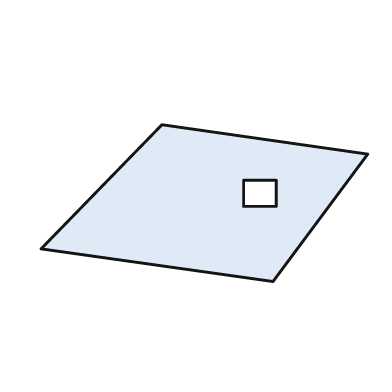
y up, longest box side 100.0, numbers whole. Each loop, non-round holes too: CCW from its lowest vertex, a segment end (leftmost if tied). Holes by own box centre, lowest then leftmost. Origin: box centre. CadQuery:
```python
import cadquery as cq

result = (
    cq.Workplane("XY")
    .moveTo(21.0, -24.0)
    .lineTo(50.0, 15.0)
    .lineTo(-13.0, 24.0)
    .lineTo(-50.0, -14.0)
    .close()
    .moveTo(12.0, -1.0)
    .lineTo(22.0, -1.0)
    .lineTo(22.0, 7.0)
    .lineTo(12.0, 7.0)
    .close()
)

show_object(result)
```